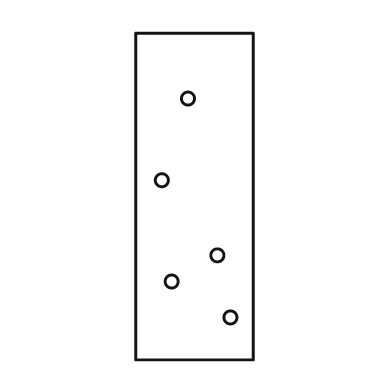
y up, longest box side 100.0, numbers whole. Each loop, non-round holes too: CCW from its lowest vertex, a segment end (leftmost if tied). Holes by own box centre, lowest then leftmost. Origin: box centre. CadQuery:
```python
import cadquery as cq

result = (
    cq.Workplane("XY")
    .moveTo(-18.0, -50.0)
    .lineTo(18.0, -50.0)
    .lineTo(18.0, 50.0)
    .lineTo(-18.0, 50.0)
    .close()
    .moveTo(11.0, -37.0)
    .circle(2.0)
    .moveTo(-7.0, -26.0)
    .circle(2.0)
    .moveTo(7.0, -18.0)
    .circle(2.0)
    .moveTo(-10.0, 5.0)
    .circle(2.0)
    .moveTo(-2.0, 30.0)
    .circle(2.0)
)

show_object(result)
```